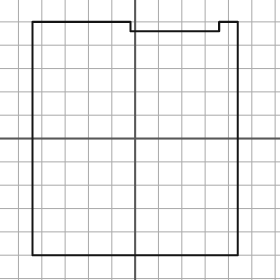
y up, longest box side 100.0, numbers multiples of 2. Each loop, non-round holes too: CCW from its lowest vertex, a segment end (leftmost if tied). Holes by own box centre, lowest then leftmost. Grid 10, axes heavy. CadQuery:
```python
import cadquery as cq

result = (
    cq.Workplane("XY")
    .moveTo(-44.0, -50.0)
    .lineTo(44.0, -50.0)
    .lineTo(44.0, 50.0)
    .lineTo(36.0, 50.0)
    .lineTo(36.0, 46.0)
    .lineTo(-2.0, 46.0)
    .lineTo(-2.0, 50.0)
    .lineTo(-44.0, 50.0)
    .close()
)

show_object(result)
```